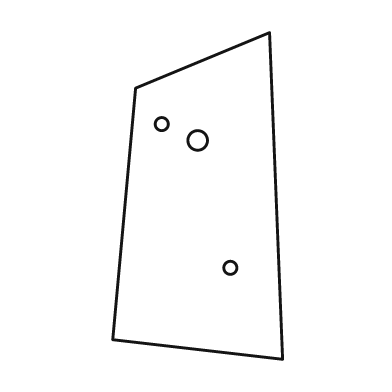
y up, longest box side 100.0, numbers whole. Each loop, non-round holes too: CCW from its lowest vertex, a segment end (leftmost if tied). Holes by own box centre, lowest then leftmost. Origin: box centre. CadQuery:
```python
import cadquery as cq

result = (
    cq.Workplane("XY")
    .moveTo(26.0, -50.0)
    .lineTo(22.0, 50.0)
    .lineTo(-19.0, 33.0)
    .lineTo(-26.0, -44.0)
    .close()
    .moveTo(10.0, -22.0)
    .circle(2.0)
    .moveTo(0.0, 17.0)
    .circle(3.0)
    .moveTo(-11.0, 22.0)
    .circle(2.0)
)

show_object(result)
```